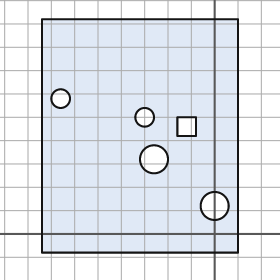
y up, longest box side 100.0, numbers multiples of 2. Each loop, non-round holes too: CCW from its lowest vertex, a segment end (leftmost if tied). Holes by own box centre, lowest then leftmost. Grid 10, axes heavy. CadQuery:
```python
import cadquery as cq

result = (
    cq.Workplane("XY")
    .moveTo(-74.0, -8.0)
    .lineTo(10.0, -8.0)
    .lineTo(10.0, 92.0)
    .lineTo(-74.0, 92.0)
    .close()
    .moveTo(0.0, 12.0)
    .circle(6.0)
    .moveTo(-26.0, 32.0)
    .circle(6.0)
    .moveTo(-16.0, 42.0)
    .lineTo(-8.0, 42.0)
    .lineTo(-8.0, 50.0)
    .lineTo(-16.0, 50.0)
    .close()
    .moveTo(-30.0, 50.0)
    .circle(4.0)
    .moveTo(-66.0, 58.0)
    .circle(4.0)
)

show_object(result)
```